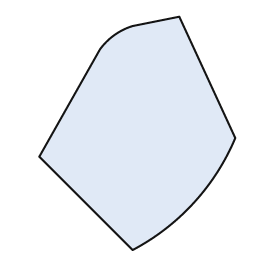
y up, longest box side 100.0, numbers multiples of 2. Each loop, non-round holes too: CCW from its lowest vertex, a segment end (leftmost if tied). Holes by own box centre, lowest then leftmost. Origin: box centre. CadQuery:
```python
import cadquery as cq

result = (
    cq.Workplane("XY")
    .moveTo(-2.0, -50.0)
    .threePointArc((24.0, -30.0), (42.0, -2.0))
    .lineTo(18.0, 50.0)
    .lineTo(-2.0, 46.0)
    .threePointArc((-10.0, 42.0), (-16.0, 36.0))
    .lineTo(-42.0, -10.0)
    .close()
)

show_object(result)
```